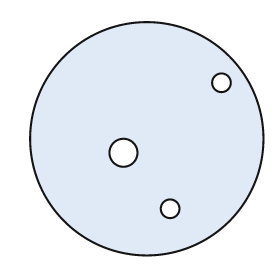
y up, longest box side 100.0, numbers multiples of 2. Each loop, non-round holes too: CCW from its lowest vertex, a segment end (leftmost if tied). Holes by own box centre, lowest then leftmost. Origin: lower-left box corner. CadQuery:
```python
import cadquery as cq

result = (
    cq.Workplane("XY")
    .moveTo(50.0, 50.0)
    .circle(50.0)
    .moveTo(60.0, 20.0)
    .circle(4.0)
    .moveTo(40.0, 44.0)
    .circle(6.0)
    .moveTo(82.0, 74.0)
    .circle(4.0)
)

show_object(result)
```